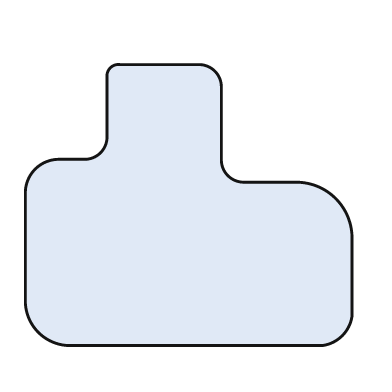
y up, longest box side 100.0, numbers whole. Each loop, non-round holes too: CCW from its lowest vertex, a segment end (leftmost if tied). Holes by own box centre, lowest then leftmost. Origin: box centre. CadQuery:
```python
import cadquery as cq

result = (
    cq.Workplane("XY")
    .moveTo(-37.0, -43.0)
    .lineTo(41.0, -43.0)
    .threePointArc((47.0, -40.0), (50.0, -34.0))
    .lineTo(50.0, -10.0)
    .threePointArc((45.0, 2.0), (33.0, 7.0))
    .lineTo(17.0, 7.0)
    .threePointArc((12.0, 9.0), (10.0, 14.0))
    .lineTo(10.0, 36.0)
    .threePointArc((8.0, 41.0), (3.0, 43.0))
    .lineTo(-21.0, 43.0)
    .threePointArc((-24.0, 42.0), (-25.0, 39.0))
    .lineTo(-25.0, 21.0)
    .threePointArc((-27.0, 16.0), (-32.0, 14.0))
    .lineTo(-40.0, 14.0)
    .threePointArc((-47.0, 11.0), (-50.0, 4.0))
    .lineTo(-50.0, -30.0)
    .threePointArc((-46.0, -39.0), (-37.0, -43.0))
    .close()
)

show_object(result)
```